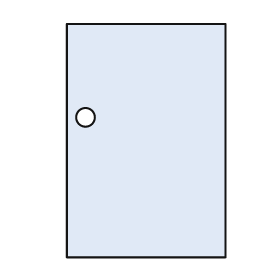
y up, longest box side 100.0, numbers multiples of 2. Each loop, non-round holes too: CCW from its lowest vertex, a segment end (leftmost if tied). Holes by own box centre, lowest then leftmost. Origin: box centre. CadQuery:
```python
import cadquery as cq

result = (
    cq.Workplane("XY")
    .moveTo(-34.0, -50.0)
    .lineTo(34.0, -50.0)
    .lineTo(34.0, 50.0)
    .lineTo(-34.0, 50.0)
    .close()
    .moveTo(-26.0, 10.0)
    .circle(4.0)
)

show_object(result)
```